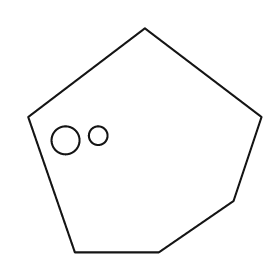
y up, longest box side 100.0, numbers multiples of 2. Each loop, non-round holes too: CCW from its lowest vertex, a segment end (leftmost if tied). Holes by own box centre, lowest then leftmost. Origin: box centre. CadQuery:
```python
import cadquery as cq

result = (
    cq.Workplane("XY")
    .moveTo(-30.0, -48.0)
    .lineTo(6.0, -48.0)
    .lineTo(38.0, -26.0)
    .lineTo(50.0, 10.0)
    .lineTo(0.0, 48.0)
    .lineTo(-50.0, 10.0)
    .close()
    .moveTo(-34.0, 0.0)
    .circle(6.0)
    .moveTo(-20.0, 2.0)
    .circle(4.0)
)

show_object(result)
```